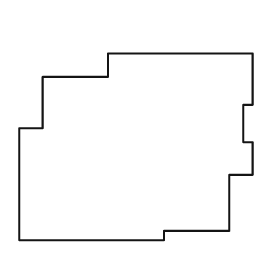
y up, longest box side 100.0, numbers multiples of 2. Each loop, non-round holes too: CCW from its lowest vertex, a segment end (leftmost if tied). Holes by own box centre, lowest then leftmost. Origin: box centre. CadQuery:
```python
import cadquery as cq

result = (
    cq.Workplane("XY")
    .moveTo(-50.0, -40.0)
    .lineTo(12.0, -40.0)
    .lineTo(12.0, -36.0)
    .lineTo(40.0, -36.0)
    .lineTo(40.0, -12.0)
    .lineTo(50.0, -12.0)
    .lineTo(50.0, 2.0)
    .lineTo(46.0, 2.0)
    .lineTo(46.0, 18.0)
    .lineTo(50.0, 18.0)
    .lineTo(50.0, 40.0)
    .lineTo(-12.0, 40.0)
    .lineTo(-12.0, 30.0)
    .lineTo(-40.0, 30.0)
    .lineTo(-40.0, 8.0)
    .lineTo(-50.0, 8.0)
    .close()
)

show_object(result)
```